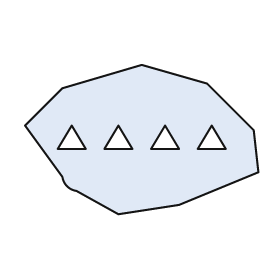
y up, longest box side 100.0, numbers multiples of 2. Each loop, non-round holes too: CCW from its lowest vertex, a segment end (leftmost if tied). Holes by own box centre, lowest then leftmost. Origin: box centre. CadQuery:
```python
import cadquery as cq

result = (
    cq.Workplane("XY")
    .moveTo(-10.0, -32.0)
    .lineTo(16.0, -28.0)
    .lineTo(50.0, -14.0)
    .lineTo(48.0, 4.0)
    .lineTo(28.0, 24.0)
    .lineTo(0.0, 32.0)
    .lineTo(-34.0, 22.0)
    .lineTo(-50.0, 6.0)
    .lineTo(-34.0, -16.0)
    .threePointArc((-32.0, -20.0), (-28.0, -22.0))
    .close()
    .moveTo(-36.0, -4.0)
    .lineTo(-24.0, -4.0)
    .lineTo(-30.0, 6.0)
    .close()
    .moveTo(-16.0, -4.0)
    .lineTo(-4.0, -4.0)
    .lineTo(-10.0, 6.0)
    .close()
    .moveTo(4.0, -4.0)
    .lineTo(16.0, -4.0)
    .lineTo(10.0, 6.0)
    .close()
    .moveTo(24.0, -4.0)
    .lineTo(36.0, -4.0)
    .lineTo(30.0, 6.0)
    .close()
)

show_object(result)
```